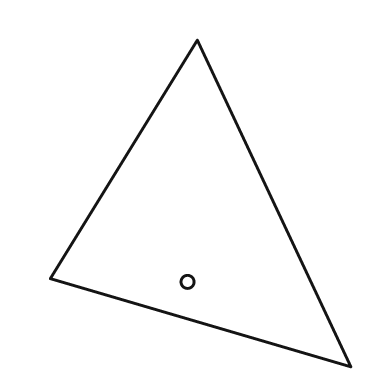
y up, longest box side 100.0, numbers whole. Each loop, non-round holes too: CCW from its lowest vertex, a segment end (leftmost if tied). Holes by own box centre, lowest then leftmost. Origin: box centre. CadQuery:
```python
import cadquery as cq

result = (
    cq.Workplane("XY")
    .moveTo(46.0, -50.0)
    .lineTo(-1.0, 50.0)
    .lineTo(-46.0, -23.0)
    .close()
    .moveTo(-4.0, -24.0)
    .circle(2.0)
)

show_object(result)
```